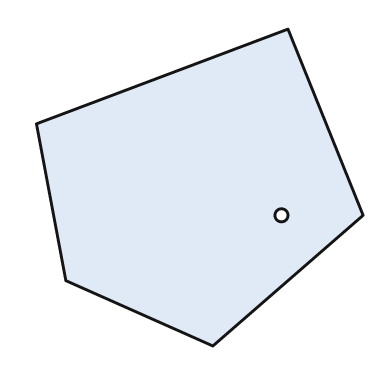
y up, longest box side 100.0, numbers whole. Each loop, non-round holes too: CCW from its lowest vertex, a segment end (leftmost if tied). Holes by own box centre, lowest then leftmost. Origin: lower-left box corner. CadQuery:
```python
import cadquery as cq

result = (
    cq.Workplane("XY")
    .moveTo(54.0, 0.0)
    .lineTo(100.0, 40.0)
    .lineTo(77.0, 97.0)
    .lineTo(0.0, 68.0)
    .lineTo(9.0, 20.0)
    .close()
    .moveTo(75.0, 40.0)
    .circle(2.0)
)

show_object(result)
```